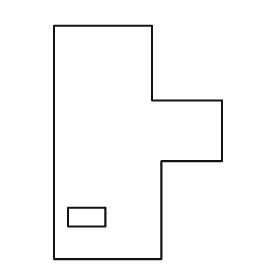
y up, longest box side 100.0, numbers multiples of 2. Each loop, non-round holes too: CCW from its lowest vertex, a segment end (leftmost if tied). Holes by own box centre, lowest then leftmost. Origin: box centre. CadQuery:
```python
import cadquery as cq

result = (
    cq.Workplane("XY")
    .moveTo(-36.0, -50.0)
    .lineTo(10.0, -50.0)
    .lineTo(10.0, -8.0)
    .lineTo(36.0, -8.0)
    .lineTo(36.0, 18.0)
    .lineTo(6.0, 18.0)
    .lineTo(6.0, 50.0)
    .lineTo(-36.0, 50.0)
    .close()
    .moveTo(-30.0, -36.0)
    .lineTo(-14.0, -36.0)
    .lineTo(-14.0, -28.0)
    .lineTo(-30.0, -28.0)
    .close()
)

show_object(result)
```